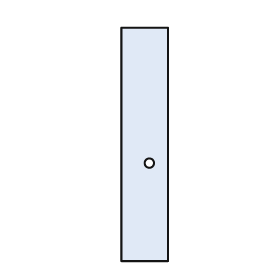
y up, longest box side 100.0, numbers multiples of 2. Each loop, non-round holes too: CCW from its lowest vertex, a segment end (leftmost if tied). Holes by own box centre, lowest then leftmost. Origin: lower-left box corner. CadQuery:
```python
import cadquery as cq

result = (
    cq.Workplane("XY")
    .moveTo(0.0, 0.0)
    .lineTo(20.0, 0.0)
    .lineTo(20.0, 100.0)
    .lineTo(0.0, 100.0)
    .close()
    .moveTo(12.0, 42.0)
    .circle(2.0)
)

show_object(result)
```